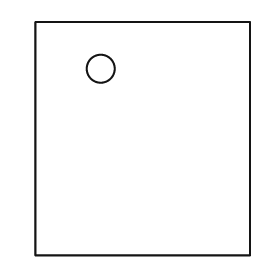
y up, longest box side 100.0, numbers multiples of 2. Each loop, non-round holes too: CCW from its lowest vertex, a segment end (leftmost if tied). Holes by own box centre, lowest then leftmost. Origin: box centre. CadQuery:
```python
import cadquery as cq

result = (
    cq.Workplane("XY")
    .moveTo(-46.0, -50.0)
    .lineTo(46.0, -50.0)
    .lineTo(46.0, 50.0)
    .lineTo(-46.0, 50.0)
    .close()
    .moveTo(-18.0, 30.0)
    .circle(6.0)
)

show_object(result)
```